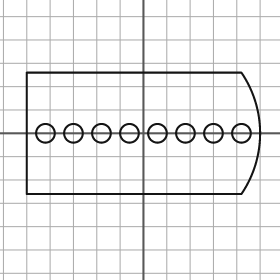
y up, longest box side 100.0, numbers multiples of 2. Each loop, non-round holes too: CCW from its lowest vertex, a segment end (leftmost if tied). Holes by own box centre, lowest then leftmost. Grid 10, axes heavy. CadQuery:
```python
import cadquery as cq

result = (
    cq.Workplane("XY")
    .moveTo(-50.0, -26.0)
    .lineTo(42.0, -26.0)
    .threePointArc((50.0, 0.0), (42.0, 26.0))
    .lineTo(-50.0, 26.0)
    .close()
    .moveTo(-42.0, 0.0)
    .circle(4.0)
    .moveTo(-30.0, 0.0)
    .circle(4.0)
    .moveTo(-18.0, 0.0)
    .circle(4.0)
    .moveTo(-6.0, 0.0)
    .circle(4.0)
    .moveTo(6.0, 0.0)
    .circle(4.0)
    .moveTo(18.0, 0.0)
    .circle(4.0)
    .moveTo(30.0, 0.0)
    .circle(4.0)
    .moveTo(42.0, 0.0)
    .circle(4.0)
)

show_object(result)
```